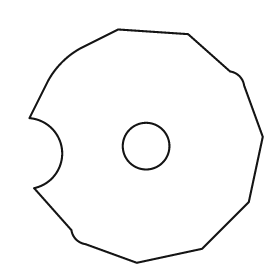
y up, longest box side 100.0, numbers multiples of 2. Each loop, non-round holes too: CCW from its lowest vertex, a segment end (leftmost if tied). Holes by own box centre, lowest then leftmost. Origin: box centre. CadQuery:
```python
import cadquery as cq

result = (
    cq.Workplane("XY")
    .moveTo(-4.0, -50.0)
    .lineTo(24.0, -44.0)
    .lineTo(44.0, -24.0)
    .lineTo(50.0, 4.0)
    .lineTo(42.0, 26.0)
    .threePointArc((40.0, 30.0), (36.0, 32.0))
    .lineTo(18.0, 48.0)
    .lineTo(-12.0, 50.0)
    .lineTo(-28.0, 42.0)
    .threePointArc((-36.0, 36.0), (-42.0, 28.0))
    .lineTo(-50.0, 12.0)
    .threePointArc((-36.0, -2.0), (-48.0, -18.0))
    .lineTo(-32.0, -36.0)
    .threePointArc((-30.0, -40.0), (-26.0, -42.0))
    .close()
    .moveTo(0.0, 0.0)
    .circle(10.0)
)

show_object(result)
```